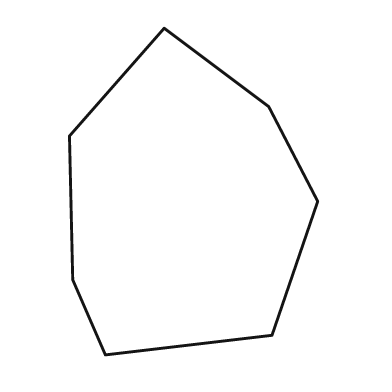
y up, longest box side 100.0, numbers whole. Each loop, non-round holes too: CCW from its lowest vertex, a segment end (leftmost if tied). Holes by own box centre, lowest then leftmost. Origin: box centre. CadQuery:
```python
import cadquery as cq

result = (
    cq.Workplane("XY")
    .moveTo(-27.0, -50.0)
    .lineTo(24.0, -44.0)
    .lineTo(38.0, -3.0)
    .lineTo(23.0, 26.0)
    .lineTo(-9.0, 50.0)
    .lineTo(-38.0, 17.0)
    .lineTo(-37.0, -27.0)
    .close()
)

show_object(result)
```